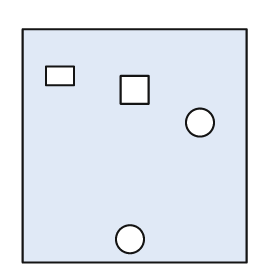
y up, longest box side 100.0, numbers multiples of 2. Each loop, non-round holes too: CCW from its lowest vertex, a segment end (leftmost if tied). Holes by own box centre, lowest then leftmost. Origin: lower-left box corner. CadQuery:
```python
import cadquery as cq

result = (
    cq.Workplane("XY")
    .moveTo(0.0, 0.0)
    .lineTo(96.0, 0.0)
    .lineTo(96.0, 100.0)
    .lineTo(0.0, 100.0)
    .close()
    .moveTo(46.0, 10.0)
    .circle(6.0)
    .moveTo(76.0, 60.0)
    .circle(6.0)
    .moveTo(42.0, 68.0)
    .lineTo(54.0, 68.0)
    .lineTo(54.0, 80.0)
    .lineTo(42.0, 80.0)
    .close()
    .moveTo(10.0, 76.0)
    .lineTo(22.0, 76.0)
    .lineTo(22.0, 84.0)
    .lineTo(10.0, 84.0)
    .close()
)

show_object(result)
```